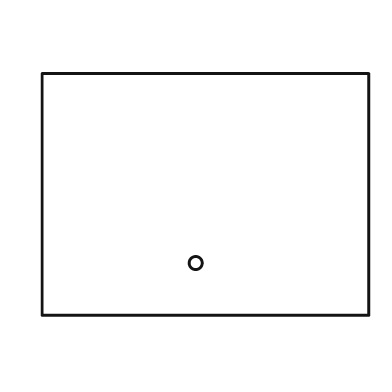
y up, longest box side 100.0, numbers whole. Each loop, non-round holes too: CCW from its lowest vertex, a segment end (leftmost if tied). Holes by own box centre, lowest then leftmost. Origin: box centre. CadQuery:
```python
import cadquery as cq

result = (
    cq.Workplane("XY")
    .moveTo(-50.0, -37.0)
    .lineTo(50.0, -37.0)
    .lineTo(50.0, 37.0)
    .lineTo(-50.0, 37.0)
    .close()
    .moveTo(-3.0, -21.0)
    .circle(2.0)
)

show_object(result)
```